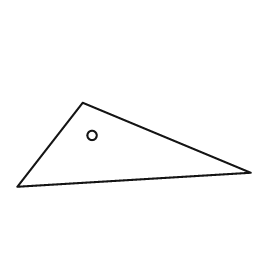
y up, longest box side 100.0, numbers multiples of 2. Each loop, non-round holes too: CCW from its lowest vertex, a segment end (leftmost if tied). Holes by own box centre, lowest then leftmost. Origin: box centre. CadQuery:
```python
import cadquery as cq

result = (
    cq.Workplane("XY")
    .moveTo(-50.0, -18.0)
    .lineTo(50.0, -12.0)
    .lineTo(-22.0, 18.0)
    .close()
    .moveTo(-18.0, 4.0)
    .circle(2.0)
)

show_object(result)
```